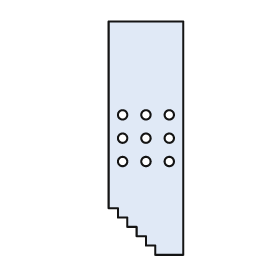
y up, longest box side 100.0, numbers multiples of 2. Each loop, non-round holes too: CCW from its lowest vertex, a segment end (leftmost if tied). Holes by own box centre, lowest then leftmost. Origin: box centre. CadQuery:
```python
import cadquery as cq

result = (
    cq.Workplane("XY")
    .moveTo(4.0, -50.0)
    .lineTo(16.0, -50.0)
    .lineTo(16.0, 50.0)
    .lineTo(-16.0, 50.0)
    .lineTo(-16.0, -30.0)
    .lineTo(-12.0, -30.0)
    .lineTo(-12.0, -34.0)
    .lineTo(-8.0, -34.0)
    .lineTo(-8.0, -38.0)
    .lineTo(-4.0, -38.0)
    .lineTo(-4.0, -42.0)
    .lineTo(0.0, -42.0)
    .lineTo(0.0, -46.0)
    .lineTo(4.0, -46.0)
    .close()
    .moveTo(-10.0, -10.0)
    .circle(2.0)
    .moveTo(0.0, -10.0)
    .circle(2.0)
    .moveTo(10.0, -10.0)
    .circle(2.0)
    .moveTo(-10.0, 0.0)
    .circle(2.0)
    .moveTo(0.0, 0.0)
    .circle(2.0)
    .moveTo(10.0, 0.0)
    .circle(2.0)
    .moveTo(-10.0, 10.0)
    .circle(2.0)
    .moveTo(0.0, 10.0)
    .circle(2.0)
    .moveTo(10.0, 10.0)
    .circle(2.0)
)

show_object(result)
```